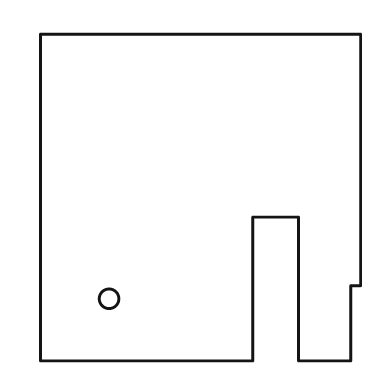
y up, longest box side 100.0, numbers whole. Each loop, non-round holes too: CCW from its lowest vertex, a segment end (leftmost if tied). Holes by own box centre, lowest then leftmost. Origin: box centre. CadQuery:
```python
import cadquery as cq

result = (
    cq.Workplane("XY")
    .moveTo(-49.0, -50.0)
    .lineTo(16.0, -50.0)
    .lineTo(16.0, -6.0)
    .lineTo(30.0, -6.0)
    .lineTo(30.0, -50.0)
    .lineTo(46.0, -50.0)
    .lineTo(46.0, -27.0)
    .lineTo(49.0, -27.0)
    .lineTo(49.0, 50.0)
    .lineTo(-49.0, 50.0)
    .close()
    .moveTo(-28.0, -31.0)
    .circle(3.0)
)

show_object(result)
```